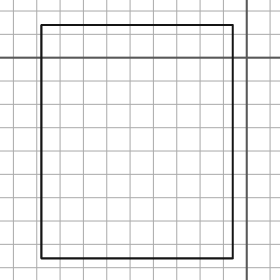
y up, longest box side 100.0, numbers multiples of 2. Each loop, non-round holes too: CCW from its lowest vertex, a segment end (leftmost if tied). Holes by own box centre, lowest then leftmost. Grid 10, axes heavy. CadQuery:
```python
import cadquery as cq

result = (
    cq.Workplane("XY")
    .moveTo(-88.0, -86.0)
    .lineTo(-6.0, -86.0)
    .lineTo(-6.0, 14.0)
    .lineTo(-88.0, 14.0)
    .close()
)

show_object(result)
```